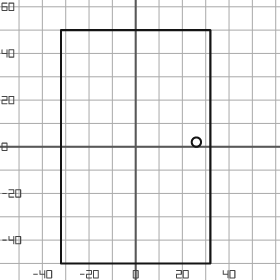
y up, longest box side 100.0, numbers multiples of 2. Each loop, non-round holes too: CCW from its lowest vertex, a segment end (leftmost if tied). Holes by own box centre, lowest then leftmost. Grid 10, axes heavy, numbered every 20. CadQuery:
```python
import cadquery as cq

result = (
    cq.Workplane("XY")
    .moveTo(-32.0, -50.0)
    .lineTo(32.0, -50.0)
    .lineTo(32.0, 50.0)
    .lineTo(-32.0, 50.0)
    .close()
    .moveTo(26.0, 2.0)
    .circle(2.0)
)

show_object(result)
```